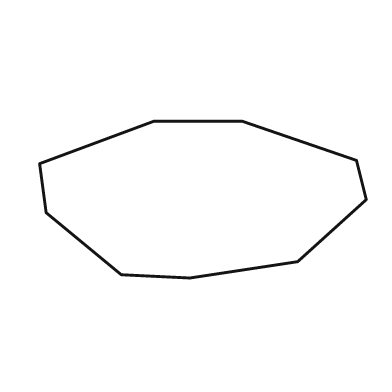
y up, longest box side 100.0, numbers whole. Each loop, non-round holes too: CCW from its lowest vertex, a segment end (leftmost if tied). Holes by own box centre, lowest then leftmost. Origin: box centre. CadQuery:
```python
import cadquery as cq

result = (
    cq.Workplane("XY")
    .moveTo(-4.0, -24.0)
    .lineTo(29.0, -19.0)
    .lineTo(50.0, 0.0)
    .lineTo(47.0, 12.0)
    .lineTo(12.0, 24.0)
    .lineTo(-15.0, 24.0)
    .lineTo(-50.0, 11.0)
    .lineTo(-48.0, -4.0)
    .lineTo(-25.0, -23.0)
    .close()
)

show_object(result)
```